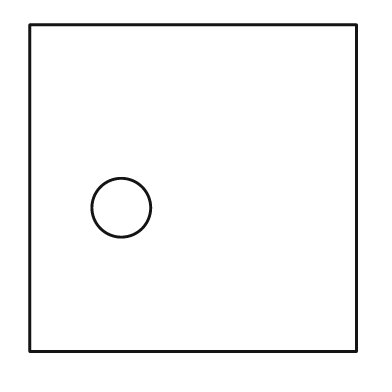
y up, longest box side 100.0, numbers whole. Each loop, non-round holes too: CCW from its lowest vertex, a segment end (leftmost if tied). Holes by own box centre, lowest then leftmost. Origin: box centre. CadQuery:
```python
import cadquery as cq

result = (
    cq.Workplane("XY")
    .moveTo(-50.0, -50.0)
    .lineTo(50.0, -50.0)
    .lineTo(50.0, 50.0)
    .lineTo(-50.0, 50.0)
    .close()
    .moveTo(-22.0, -6.0)
    .circle(9.0)
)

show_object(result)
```